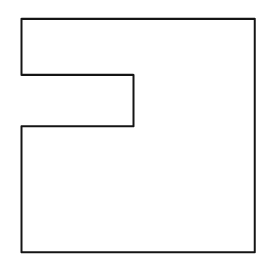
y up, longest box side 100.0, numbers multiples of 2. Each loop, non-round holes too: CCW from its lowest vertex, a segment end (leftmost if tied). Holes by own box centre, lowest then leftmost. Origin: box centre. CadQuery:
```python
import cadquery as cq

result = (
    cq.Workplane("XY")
    .moveTo(-50.0, -50.0)
    .lineTo(50.0, -50.0)
    .lineTo(50.0, 50.0)
    .lineTo(-50.0, 50.0)
    .lineTo(-50.0, 26.0)
    .lineTo(-2.0, 26.0)
    .lineTo(-2.0, 4.0)
    .lineTo(-50.0, 4.0)
    .close()
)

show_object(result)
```